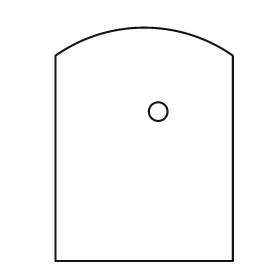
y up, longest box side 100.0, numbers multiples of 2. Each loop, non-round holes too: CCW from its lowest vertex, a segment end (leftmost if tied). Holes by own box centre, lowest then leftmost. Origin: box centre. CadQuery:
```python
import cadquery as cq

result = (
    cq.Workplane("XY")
    .moveTo(-38.0, -50.0)
    .lineTo(38.0, -50.0)
    .lineTo(38.0, 38.0)
    .threePointArc((0.0, 50.0), (-38.0, 38.0))
    .close()
    .moveTo(6.0, 14.0)
    .circle(4.0)
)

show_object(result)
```